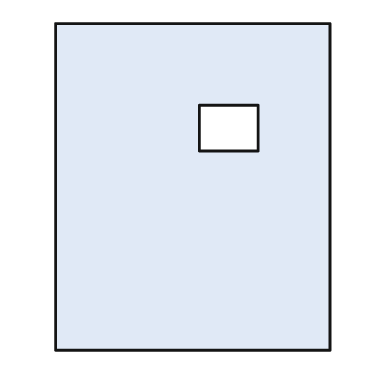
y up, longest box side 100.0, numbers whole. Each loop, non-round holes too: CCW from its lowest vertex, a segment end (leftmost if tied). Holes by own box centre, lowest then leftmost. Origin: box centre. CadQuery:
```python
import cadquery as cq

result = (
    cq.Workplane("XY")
    .moveTo(-42.0, -50.0)
    .lineTo(42.0, -50.0)
    .lineTo(42.0, 50.0)
    .lineTo(-42.0, 50.0)
    .close()
    .moveTo(2.0, 11.0)
    .lineTo(20.0, 11.0)
    .lineTo(20.0, 25.0)
    .lineTo(2.0, 25.0)
    .close()
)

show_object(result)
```